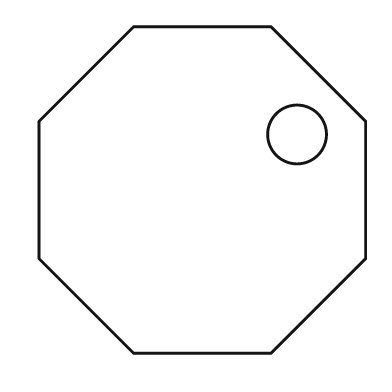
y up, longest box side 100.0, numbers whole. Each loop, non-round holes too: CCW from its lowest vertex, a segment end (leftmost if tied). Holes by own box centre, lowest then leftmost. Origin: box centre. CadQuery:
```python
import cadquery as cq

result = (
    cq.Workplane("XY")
    .moveTo(-21.0, -50.0)
    .lineTo(21.0, -50.0)
    .lineTo(50.0, -21.0)
    .lineTo(50.0, 21.0)
    .lineTo(21.0, 50.0)
    .lineTo(-21.0, 50.0)
    .lineTo(-50.0, 21.0)
    .lineTo(-50.0, -21.0)
    .close()
    .moveTo(29.0, 17.0)
    .circle(9.0)
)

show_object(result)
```